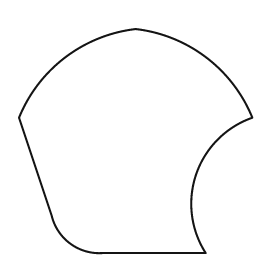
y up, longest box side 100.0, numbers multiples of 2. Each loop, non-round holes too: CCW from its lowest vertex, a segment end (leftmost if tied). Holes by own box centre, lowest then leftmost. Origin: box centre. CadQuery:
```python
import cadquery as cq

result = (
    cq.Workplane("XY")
    .moveTo(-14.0, -48.0)
    .lineTo(30.0, -48.0)
    .threePointArc((26.0, -14.0), (50.0, 10.0))
    .threePointArc((30.0, 36.0), (0.0, 48.0))
    .threePointArc((-30.0, 36.0), (-50.0, 10.0))
    .lineTo(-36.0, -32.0)
    .threePointArc((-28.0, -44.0), (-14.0, -48.0))
    .close()
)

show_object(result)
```